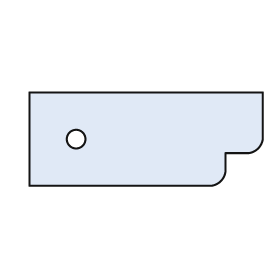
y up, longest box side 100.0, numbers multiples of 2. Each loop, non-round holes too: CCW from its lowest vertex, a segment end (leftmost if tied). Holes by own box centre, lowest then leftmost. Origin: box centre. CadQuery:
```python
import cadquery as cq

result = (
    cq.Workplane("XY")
    .moveTo(-50.0, -20.0)
    .lineTo(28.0, -20.0)
    .threePointArc((32.0, -18.0), (34.0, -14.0))
    .lineTo(34.0, -6.0)
    .lineTo(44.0, -6.0)
    .threePointArc((48.0, -4.0), (50.0, 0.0))
    .lineTo(50.0, 20.0)
    .lineTo(-50.0, 20.0)
    .close()
    .moveTo(-30.0, 0.0)
    .circle(4.0)
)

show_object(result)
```